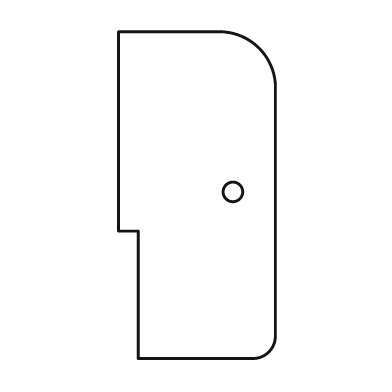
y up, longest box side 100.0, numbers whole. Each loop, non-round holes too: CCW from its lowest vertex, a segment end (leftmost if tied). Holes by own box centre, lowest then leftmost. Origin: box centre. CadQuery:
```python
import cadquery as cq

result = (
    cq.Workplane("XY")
    .moveTo(-18.0, -50.0)
    .lineTo(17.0, -50.0)
    .threePointArc((22.0, -48.0), (24.0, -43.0))
    .lineTo(24.0, 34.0)
    .threePointArc((19.0, 45.0), (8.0, 50.0))
    .lineTo(-24.0, 50.0)
    .lineTo(-24.0, -11.0)
    .lineTo(-18.0, -11.0)
    .close()
    .moveTo(11.0, 1.0)
    .circle(3.0)
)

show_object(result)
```